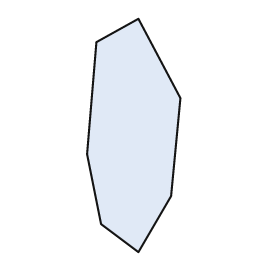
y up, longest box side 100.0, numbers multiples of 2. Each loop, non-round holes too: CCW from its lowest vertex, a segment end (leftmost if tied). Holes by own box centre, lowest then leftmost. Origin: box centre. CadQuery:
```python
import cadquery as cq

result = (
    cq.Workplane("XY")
    .moveTo(2.0, -50.0)
    .lineTo(16.0, -26.0)
    .lineTo(20.0, 16.0)
    .lineTo(2.0, 50.0)
    .lineTo(-16.0, 40.0)
    .lineTo(-20.0, -8.0)
    .lineTo(-14.0, -38.0)
    .close()
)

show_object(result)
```